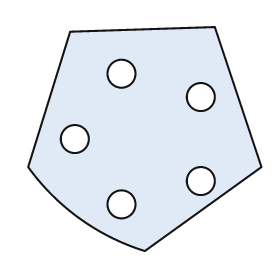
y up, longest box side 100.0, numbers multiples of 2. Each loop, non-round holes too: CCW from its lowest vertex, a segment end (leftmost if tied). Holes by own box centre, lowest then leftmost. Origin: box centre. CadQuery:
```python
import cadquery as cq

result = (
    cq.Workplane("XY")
    .moveTo(0.0, -48.0)
    .lineTo(50.0, -12.0)
    .lineTo(30.0, 48.0)
    .lineTo(-32.0, 46.0)
    .lineTo(-50.0, -12.0)
    .threePointArc((-28.0, -34.0), (0.0, -48.0))
    .close()
    .moveTo(-10.0, -28.0)
    .circle(6.0)
    .moveTo(24.0, -18.0)
    .circle(6.0)
    .moveTo(-30.0, 0.0)
    .circle(6.0)
    .moveTo(24.0, 18.0)
    .circle(6.0)
    .moveTo(-10.0, 28.0)
    .circle(6.0)
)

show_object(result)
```